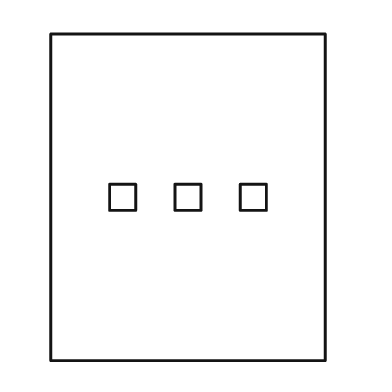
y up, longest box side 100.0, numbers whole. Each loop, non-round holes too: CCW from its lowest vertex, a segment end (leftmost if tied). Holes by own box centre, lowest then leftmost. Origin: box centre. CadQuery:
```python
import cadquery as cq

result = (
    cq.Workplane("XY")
    .moveTo(-42.0, -50.0)
    .lineTo(42.0, -50.0)
    .lineTo(42.0, 50.0)
    .lineTo(-42.0, 50.0)
    .close()
    .moveTo(-24.0, -4.0)
    .lineTo(-16.0, -4.0)
    .lineTo(-16.0, 4.0)
    .lineTo(-24.0, 4.0)
    .close()
    .moveTo(-4.0, -4.0)
    .lineTo(4.0, -4.0)
    .lineTo(4.0, 4.0)
    .lineTo(-4.0, 4.0)
    .close()
    .moveTo(16.0, -4.0)
    .lineTo(24.0, -4.0)
    .lineTo(24.0, 4.0)
    .lineTo(16.0, 4.0)
    .close()
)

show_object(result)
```